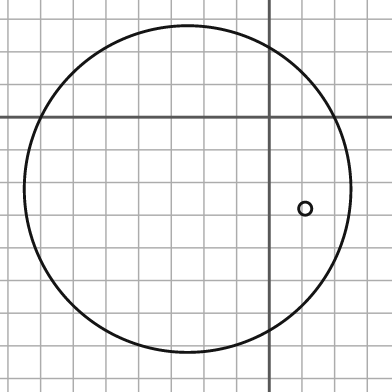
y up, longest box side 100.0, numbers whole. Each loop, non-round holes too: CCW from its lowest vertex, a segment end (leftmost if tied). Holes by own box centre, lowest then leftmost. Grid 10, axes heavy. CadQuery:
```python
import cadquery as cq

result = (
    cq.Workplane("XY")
    .moveTo(-25.0, -22.0)
    .circle(50.0)
    .moveTo(11.0, -28.0)
    .circle(2.0)
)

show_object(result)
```